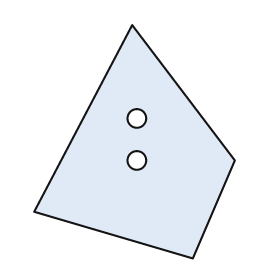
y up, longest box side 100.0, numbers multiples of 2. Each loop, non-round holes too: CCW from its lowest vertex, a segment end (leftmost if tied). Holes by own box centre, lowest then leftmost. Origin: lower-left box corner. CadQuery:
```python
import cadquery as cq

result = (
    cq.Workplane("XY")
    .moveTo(68.0, 0.0)
    .lineTo(86.0, 42.0)
    .lineTo(42.0, 100.0)
    .lineTo(0.0, 20.0)
    .close()
    .moveTo(44.0, 42.0)
    .circle(4.0)
    .moveTo(44.0, 60.0)
    .circle(4.0)
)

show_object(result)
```